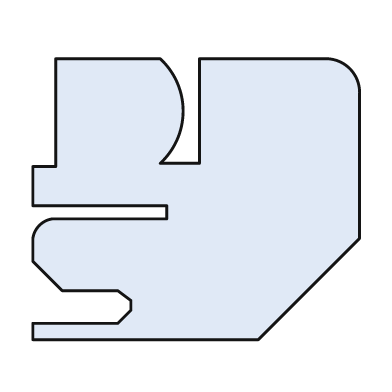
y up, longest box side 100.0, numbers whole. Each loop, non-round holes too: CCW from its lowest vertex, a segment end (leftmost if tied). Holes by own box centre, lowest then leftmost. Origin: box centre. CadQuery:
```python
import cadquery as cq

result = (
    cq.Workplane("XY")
    .moveTo(-50.0, -43.0)
    .lineTo(19.0, -43.0)
    .lineTo(50.0, -12.0)
    .lineTo(50.0, 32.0)
    .threePointArc((47.0, 40.0), (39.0, 43.0))
    .lineTo(1.0, 43.0)
    .lineTo(1.0, 11.0)
    .lineTo(-11.0, 11.0)
    .threePointArc((-4.0, 27.0), (-11.0, 43.0))
    .lineTo(-43.0, 43.0)
    .lineTo(-43.0, 10.0)
    .lineTo(-50.0, 10.0)
    .lineTo(-50.0, -2.0)
    .lineTo(-9.0, -2.0)
    .lineTo(-9.0, -6.0)
    .lineTo(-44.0, -6.0)
    .threePointArc((-48.0, -8.0), (-50.0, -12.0))
    .lineTo(-50.0, -19.0)
    .lineTo(-41.0, -28.0)
    .lineTo(-24.0, -28.0)
    .lineTo(-20.0, -31.0)
    .lineTo(-20.0, -34.0)
    .lineTo(-24.0, -38.0)
    .lineTo(-50.0, -38.0)
    .close()
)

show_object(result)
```